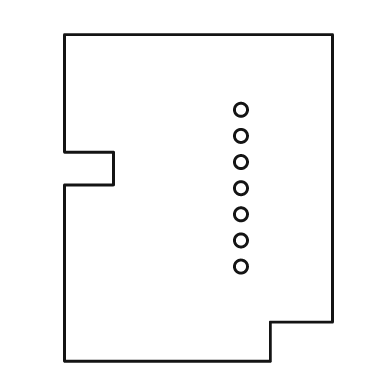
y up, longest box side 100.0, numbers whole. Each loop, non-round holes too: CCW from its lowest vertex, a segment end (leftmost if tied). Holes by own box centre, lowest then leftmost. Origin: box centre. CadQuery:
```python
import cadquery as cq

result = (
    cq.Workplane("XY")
    .moveTo(-41.0, -50.0)
    .lineTo(22.0, -50.0)
    .lineTo(22.0, -38.0)
    .lineTo(41.0, -38.0)
    .lineTo(41.0, 50.0)
    .lineTo(-41.0, 50.0)
    .lineTo(-41.0, 14.0)
    .lineTo(-26.0, 14.0)
    .lineTo(-26.0, 4.0)
    .lineTo(-41.0, 4.0)
    .close()
    .moveTo(13.0, -21.0)
    .circle(2.0)
    .moveTo(13.0, -13.0)
    .circle(2.0)
    .moveTo(13.0, -5.0)
    .circle(2.0)
    .moveTo(13.0, 3.0)
    .circle(2.0)
    .moveTo(13.0, 11.0)
    .circle(2.0)
    .moveTo(13.0, 19.0)
    .circle(2.0)
    .moveTo(13.0, 27.0)
    .circle(2.0)
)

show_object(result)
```